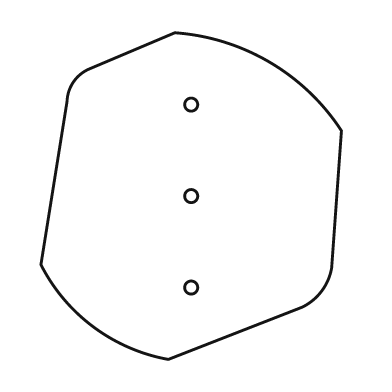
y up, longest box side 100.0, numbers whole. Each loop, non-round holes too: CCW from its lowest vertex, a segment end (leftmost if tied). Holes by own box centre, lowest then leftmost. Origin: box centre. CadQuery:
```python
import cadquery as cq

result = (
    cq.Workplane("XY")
    .moveTo(-7.0, -50.0)
    .lineTo(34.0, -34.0)
    .threePointArc((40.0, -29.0), (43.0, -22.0))
    .lineTo(46.0, 20.0)
    .threePointArc((24.0, 41.0), (-5.0, 50.0))
    .lineTo(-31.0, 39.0)
    .threePointArc((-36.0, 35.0), (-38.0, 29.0))
    .lineTo(-46.0, -21.0)
    .threePointArc((-30.0, -40.0), (-7.0, -50.0))
    .close()
    .moveTo(0.0, -28.0)
    .circle(2.0)
    .moveTo(0.0, 0.0)
    .circle(2.0)
    .moveTo(0.0, 28.0)
    .circle(2.0)
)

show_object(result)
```